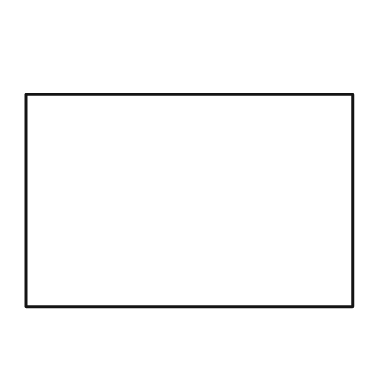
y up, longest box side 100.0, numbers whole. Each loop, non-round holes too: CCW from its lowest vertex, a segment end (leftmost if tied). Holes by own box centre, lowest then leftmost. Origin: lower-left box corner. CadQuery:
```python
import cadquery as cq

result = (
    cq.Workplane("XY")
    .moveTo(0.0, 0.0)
    .lineTo(100.0, 0.0)
    .lineTo(100.0, 65.0)
    .lineTo(0.0, 65.0)
    .close()
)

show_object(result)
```